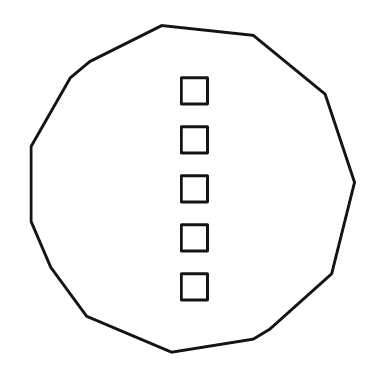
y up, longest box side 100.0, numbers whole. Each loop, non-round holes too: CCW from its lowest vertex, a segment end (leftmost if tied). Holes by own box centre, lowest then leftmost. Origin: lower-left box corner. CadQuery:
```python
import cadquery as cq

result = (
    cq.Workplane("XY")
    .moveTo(43.0, 0.0)
    .lineTo(68.0, 4.0)
    .lineTo(73.0, 7.0)
    .lineTo(92.0, 24.0)
    .lineTo(99.0, 52.0)
    .lineTo(90.0, 79.0)
    .lineTo(68.0, 97.0)
    .lineTo(40.0, 100.0)
    .lineTo(18.0, 89.0)
    .lineTo(12.0, 84.0)
    .lineTo(0.0, 63.0)
    .lineTo(0.0, 40.0)
    .lineTo(6.0, 26.0)
    .lineTo(17.0, 11.0)
    .close()
    .moveTo(46.0, 16.0)
    .lineTo(54.0, 16.0)
    .lineTo(54.0, 24.0)
    .lineTo(46.0, 24.0)
    .close()
    .moveTo(46.0, 31.0)
    .lineTo(54.0, 31.0)
    .lineTo(54.0, 39.0)
    .lineTo(46.0, 39.0)
    .close()
    .moveTo(46.0, 46.0)
    .lineTo(54.0, 46.0)
    .lineTo(54.0, 54.0)
    .lineTo(46.0, 54.0)
    .close()
    .moveTo(46.0, 61.0)
    .lineTo(54.0, 61.0)
    .lineTo(54.0, 69.0)
    .lineTo(46.0, 69.0)
    .close()
    .moveTo(46.0, 76.0)
    .lineTo(54.0, 76.0)
    .lineTo(54.0, 84.0)
    .lineTo(46.0, 84.0)
    .close()
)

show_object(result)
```